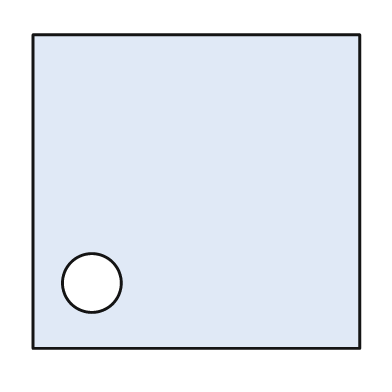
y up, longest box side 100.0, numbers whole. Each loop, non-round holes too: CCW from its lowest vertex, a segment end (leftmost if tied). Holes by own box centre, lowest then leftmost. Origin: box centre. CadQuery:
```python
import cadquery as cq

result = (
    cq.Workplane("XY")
    .moveTo(-50.0, -48.0)
    .lineTo(50.0, -48.0)
    .lineTo(50.0, 48.0)
    .lineTo(-50.0, 48.0)
    .close()
    .moveTo(-32.0, -28.0)
    .circle(9.0)
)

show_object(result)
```